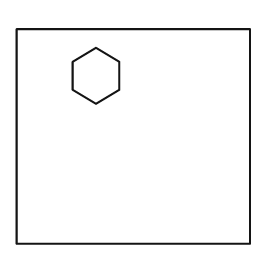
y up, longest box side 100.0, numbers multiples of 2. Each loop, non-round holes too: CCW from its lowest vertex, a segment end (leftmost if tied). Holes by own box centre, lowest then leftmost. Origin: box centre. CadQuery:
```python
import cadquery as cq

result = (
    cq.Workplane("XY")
    .moveTo(-50.0, -46.0)
    .lineTo(50.0, -46.0)
    .lineTo(50.0, 46.0)
    .lineTo(-50.0, 46.0)
    .close()
    .moveTo(-16.0, 14.0)
    .lineTo(-6.0, 20.0)
    .lineTo(-6.0, 32.0)
    .lineTo(-16.0, 38.0)
    .lineTo(-26.0, 32.0)
    .lineTo(-26.0, 20.0)
    .close()
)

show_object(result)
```